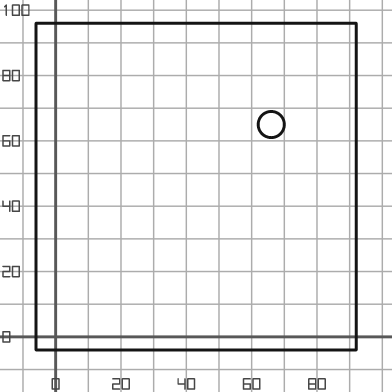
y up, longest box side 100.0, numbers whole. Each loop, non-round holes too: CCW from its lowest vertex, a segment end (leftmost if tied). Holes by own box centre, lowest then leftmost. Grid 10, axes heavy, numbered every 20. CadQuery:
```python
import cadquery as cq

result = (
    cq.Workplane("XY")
    .moveTo(-6.0, -4.0)
    .lineTo(92.0, -4.0)
    .lineTo(92.0, 96.0)
    .lineTo(-6.0, 96.0)
    .close()
    .moveTo(66.0, 65.0)
    .circle(4.0)
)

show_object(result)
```